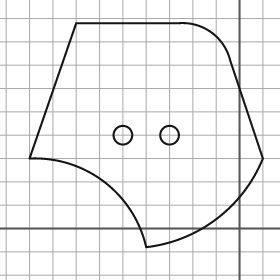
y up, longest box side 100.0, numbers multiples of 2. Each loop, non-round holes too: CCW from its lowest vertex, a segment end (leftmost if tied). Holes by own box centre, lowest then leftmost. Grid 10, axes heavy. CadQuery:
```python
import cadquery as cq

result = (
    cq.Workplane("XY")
    .moveTo(-40.0, -8.0)
    .threePointArc((-10.0, 4.0), (10.0, 30.0))
    .lineTo(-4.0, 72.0)
    .threePointArc((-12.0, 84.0), (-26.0, 88.0))
    .lineTo(-70.0, 88.0)
    .lineTo(-90.0, 30.0)
    .threePointArc((-58.0, 20.0), (-40.0, -8.0))
    .close()
    .moveTo(-50.0, 40.0)
    .circle(4.0)
    .moveTo(-30.0, 40.0)
    .circle(4.0)
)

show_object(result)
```